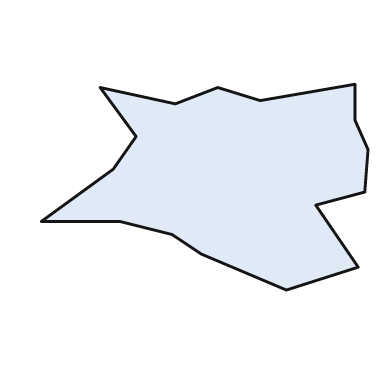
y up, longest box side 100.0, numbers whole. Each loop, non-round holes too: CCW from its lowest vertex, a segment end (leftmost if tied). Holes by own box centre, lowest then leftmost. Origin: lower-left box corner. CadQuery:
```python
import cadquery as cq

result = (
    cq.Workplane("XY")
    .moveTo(75.0, 0.0)
    .lineTo(97.0, 7.0)
    .lineTo(84.0, 26.0)
    .lineTo(99.0, 30.0)
    .lineTo(100.0, 43.0)
    .lineTo(96.0, 52.0)
    .lineTo(96.0, 63.0)
    .lineTo(67.0, 58.0)
    .lineTo(54.0, 62.0)
    .lineTo(41.0, 57.0)
    .lineTo(18.0, 62.0)
    .lineTo(29.0, 47.0)
    .lineTo(22.0, 37.0)
    .lineTo(0.0, 21.0)
    .lineTo(24.0, 21.0)
    .lineTo(40.0, 17.0)
    .lineTo(49.0, 11.0)
    .close()
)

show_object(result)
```